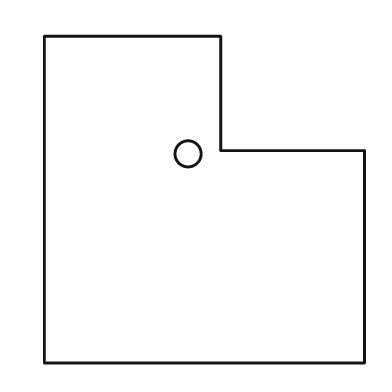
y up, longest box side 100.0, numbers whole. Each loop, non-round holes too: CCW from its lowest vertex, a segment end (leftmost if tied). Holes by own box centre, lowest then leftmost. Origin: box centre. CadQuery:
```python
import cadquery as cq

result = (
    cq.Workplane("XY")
    .moveTo(-49.0, -50.0)
    .lineTo(49.0, -50.0)
    .lineTo(49.0, 15.0)
    .lineTo(5.0, 15.0)
    .lineTo(5.0, 50.0)
    .lineTo(-49.0, 50.0)
    .close()
    .moveTo(-5.0, 14.0)
    .circle(4.0)
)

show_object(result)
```